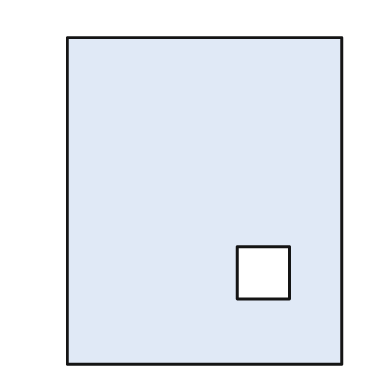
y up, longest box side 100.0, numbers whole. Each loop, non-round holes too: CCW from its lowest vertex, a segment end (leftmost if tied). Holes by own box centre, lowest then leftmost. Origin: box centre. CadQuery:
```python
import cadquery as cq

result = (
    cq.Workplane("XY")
    .moveTo(-42.0, -50.0)
    .lineTo(42.0, -50.0)
    .lineTo(42.0, 50.0)
    .lineTo(-42.0, 50.0)
    .close()
    .moveTo(10.0, -30.0)
    .lineTo(26.0, -30.0)
    .lineTo(26.0, -14.0)
    .lineTo(10.0, -14.0)
    .close()
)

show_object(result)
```